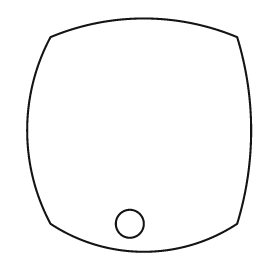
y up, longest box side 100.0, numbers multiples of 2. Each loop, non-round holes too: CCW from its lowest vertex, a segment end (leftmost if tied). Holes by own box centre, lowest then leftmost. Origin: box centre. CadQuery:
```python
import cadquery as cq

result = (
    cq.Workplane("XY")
    .moveTo(-38.0, -38.0)
    .threePointArc((2.0, -50.0), (42.0, -38.0))
    .threePointArc((48.0, 2.0), (42.0, 42.0))
    .threePointArc((2.0, 50.0), (-38.0, 42.0))
    .threePointArc((-48.0, 2.0), (-38.0, -38.0))
    .close()
    .moveTo(-4.0, -38.0)
    .circle(6.0)
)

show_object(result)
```